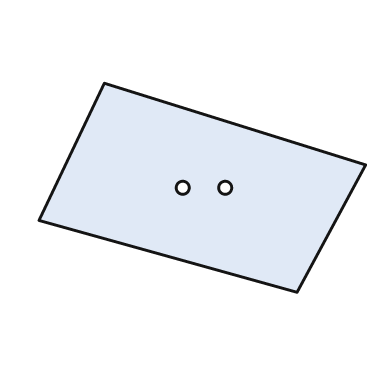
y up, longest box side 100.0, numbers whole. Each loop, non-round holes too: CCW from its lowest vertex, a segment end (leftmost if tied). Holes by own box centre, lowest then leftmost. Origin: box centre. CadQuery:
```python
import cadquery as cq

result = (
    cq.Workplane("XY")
    .moveTo(29.0, -32.0)
    .lineTo(50.0, 7.0)
    .lineTo(-30.0, 32.0)
    .lineTo(-50.0, -10.0)
    .close()
    .moveTo(-6.0, 0.0)
    .circle(2.0)
    .moveTo(7.0, 0.0)
    .circle(2.0)
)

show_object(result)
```